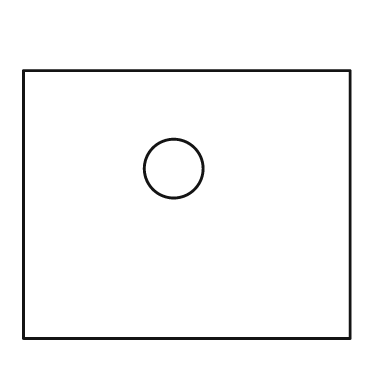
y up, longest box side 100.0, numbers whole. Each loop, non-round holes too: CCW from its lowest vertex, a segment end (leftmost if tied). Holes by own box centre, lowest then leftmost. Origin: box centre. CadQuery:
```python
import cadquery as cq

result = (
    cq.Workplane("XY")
    .moveTo(-50.0, -41.0)
    .lineTo(50.0, -41.0)
    .lineTo(50.0, 41.0)
    .lineTo(-50.0, 41.0)
    .close()
    .moveTo(-4.0, 11.0)
    .circle(9.0)
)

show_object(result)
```